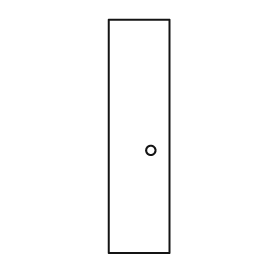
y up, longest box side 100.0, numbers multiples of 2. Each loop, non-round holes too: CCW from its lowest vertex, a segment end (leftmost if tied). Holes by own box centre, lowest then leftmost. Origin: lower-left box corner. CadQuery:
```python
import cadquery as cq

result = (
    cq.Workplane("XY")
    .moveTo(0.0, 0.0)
    .lineTo(26.0, 0.0)
    .lineTo(26.0, 100.0)
    .lineTo(0.0, 100.0)
    .close()
    .moveTo(18.0, 44.0)
    .circle(2.0)
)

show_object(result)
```